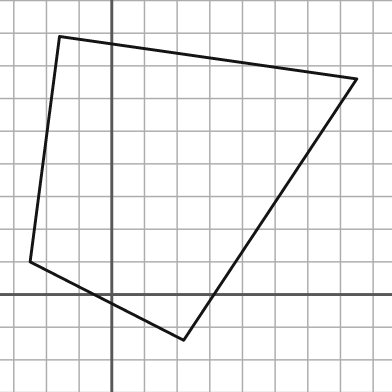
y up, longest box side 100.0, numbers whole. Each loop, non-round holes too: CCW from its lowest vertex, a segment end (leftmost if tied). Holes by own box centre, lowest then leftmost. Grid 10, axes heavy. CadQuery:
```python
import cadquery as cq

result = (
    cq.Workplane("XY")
    .moveTo(22.0, -14.0)
    .lineTo(75.0, 66.0)
    .lineTo(-16.0, 79.0)
    .lineTo(-25.0, 10.0)
    .close()
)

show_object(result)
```